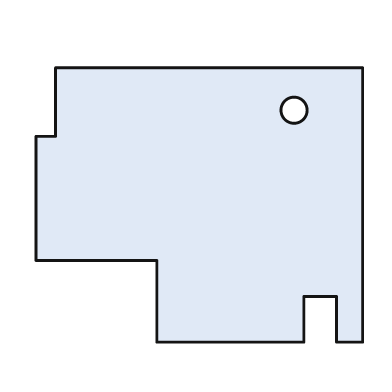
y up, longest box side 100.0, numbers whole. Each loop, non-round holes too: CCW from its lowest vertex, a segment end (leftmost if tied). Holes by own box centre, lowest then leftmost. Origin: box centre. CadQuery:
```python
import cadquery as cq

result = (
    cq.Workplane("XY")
    .moveTo(-13.0, -42.0)
    .lineTo(32.0, -42.0)
    .lineTo(32.0, -28.0)
    .lineTo(42.0, -28.0)
    .lineTo(42.0, -42.0)
    .lineTo(50.0, -42.0)
    .lineTo(50.0, 42.0)
    .lineTo(-44.0, 42.0)
    .lineTo(-44.0, 21.0)
    .lineTo(-50.0, 21.0)
    .lineTo(-50.0, -17.0)
    .lineTo(-13.0, -17.0)
    .close()
    .moveTo(29.0, 29.0)
    .circle(4.0)
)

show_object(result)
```